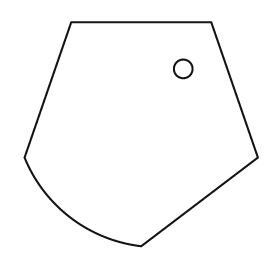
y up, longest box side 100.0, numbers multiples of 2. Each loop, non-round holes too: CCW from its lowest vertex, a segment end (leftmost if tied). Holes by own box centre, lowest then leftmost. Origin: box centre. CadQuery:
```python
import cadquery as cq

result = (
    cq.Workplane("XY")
    .moveTo(0.0, -48.0)
    .lineTo(50.0, -10.0)
    .lineTo(30.0, 48.0)
    .lineTo(-30.0, 48.0)
    .lineTo(-50.0, -10.0)
    .threePointArc((-30.0, -36.0), (0.0, -48.0))
    .close()
    .moveTo(18.0, 28.0)
    .circle(4.0)
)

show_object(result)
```